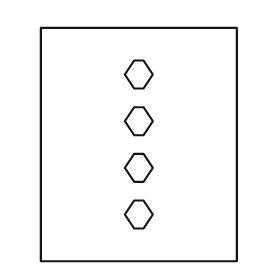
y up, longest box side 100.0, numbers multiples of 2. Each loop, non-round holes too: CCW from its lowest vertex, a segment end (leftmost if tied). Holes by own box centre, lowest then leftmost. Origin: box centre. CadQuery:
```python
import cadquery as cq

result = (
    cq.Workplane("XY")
    .moveTo(-42.0, -50.0)
    .lineTo(42.0, -50.0)
    .lineTo(42.0, 50.0)
    .lineTo(-42.0, 50.0)
    .close()
    .moveTo(-2.0, -36.0)
    .lineTo(2.0, -36.0)
    .lineTo(6.0, -30.0)
    .lineTo(2.0, -24.0)
    .lineTo(-2.0, -24.0)
    .lineTo(-6.0, -30.0)
    .close()
    .moveTo(-2.0, -16.0)
    .lineTo(2.0, -16.0)
    .lineTo(6.0, -10.0)
    .lineTo(2.0, -4.0)
    .lineTo(-2.0, -4.0)
    .lineTo(-6.0, -10.0)
    .close()
    .moveTo(-2.0, 4.0)
    .lineTo(2.0, 4.0)
    .lineTo(6.0, 10.0)
    .lineTo(2.0, 16.0)
    .lineTo(-2.0, 16.0)
    .lineTo(-6.0, 10.0)
    .close()
    .moveTo(-2.0, 24.0)
    .lineTo(2.0, 24.0)
    .lineTo(6.0, 30.0)
    .lineTo(2.0, 36.0)
    .lineTo(-2.0, 36.0)
    .lineTo(-6.0, 30.0)
    .close()
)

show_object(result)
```